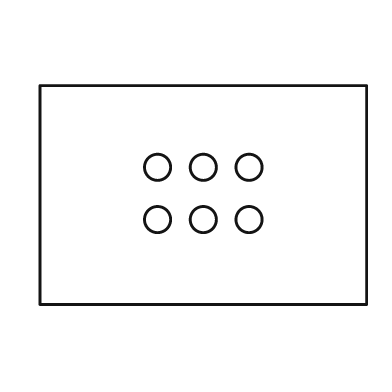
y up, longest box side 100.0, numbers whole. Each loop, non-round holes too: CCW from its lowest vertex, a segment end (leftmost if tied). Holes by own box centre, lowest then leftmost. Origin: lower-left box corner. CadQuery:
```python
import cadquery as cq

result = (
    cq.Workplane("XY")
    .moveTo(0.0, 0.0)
    .lineTo(100.0, 0.0)
    .lineTo(100.0, 67.0)
    .lineTo(0.0, 67.0)
    .close()
    .moveTo(36.0, 26.0)
    .circle(4.0)
    .moveTo(50.0, 26.0)
    .circle(4.0)
    .moveTo(64.0, 26.0)
    .circle(4.0)
    .moveTo(36.0, 42.0)
    .circle(4.0)
    .moveTo(50.0, 42.0)
    .circle(4.0)
    .moveTo(64.0, 42.0)
    .circle(4.0)
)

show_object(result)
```